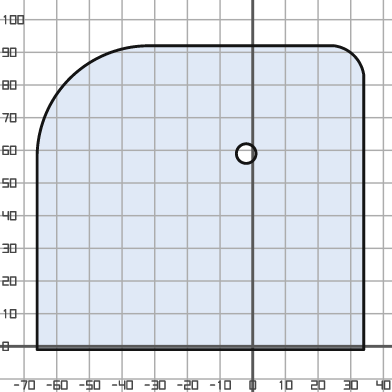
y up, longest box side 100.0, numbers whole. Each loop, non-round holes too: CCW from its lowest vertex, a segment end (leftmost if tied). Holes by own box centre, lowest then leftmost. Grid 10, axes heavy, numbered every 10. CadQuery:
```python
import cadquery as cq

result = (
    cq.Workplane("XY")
    .moveTo(-66.0, -1.0)
    .lineTo(34.0, -1.0)
    .lineTo(34.0, 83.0)
    .threePointArc((31.0, 89.0), (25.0, 92.0))
    .lineTo(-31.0, 92.0)
    .threePointArc((-56.0, 82.0), (-66.0, 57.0))
    .close()
    .moveTo(-2.0, 59.0)
    .circle(3.0)
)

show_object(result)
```